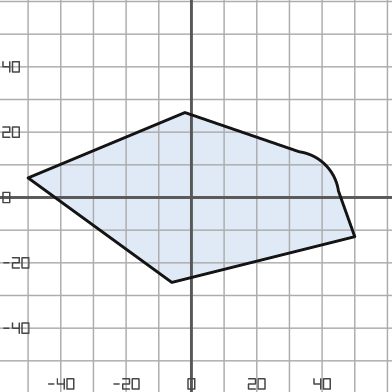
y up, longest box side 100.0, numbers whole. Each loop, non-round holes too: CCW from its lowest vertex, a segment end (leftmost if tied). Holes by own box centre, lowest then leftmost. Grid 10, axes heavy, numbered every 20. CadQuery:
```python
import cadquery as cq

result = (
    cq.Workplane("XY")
    .moveTo(-6.0, -26.0)
    .lineTo(50.0, -12.0)
    .lineTo(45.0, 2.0)
    .threePointArc((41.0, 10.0), (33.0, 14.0))
    .lineTo(-2.0, 26.0)
    .lineTo(-50.0, 6.0)
    .close()
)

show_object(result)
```